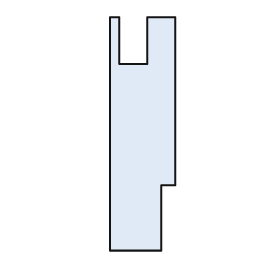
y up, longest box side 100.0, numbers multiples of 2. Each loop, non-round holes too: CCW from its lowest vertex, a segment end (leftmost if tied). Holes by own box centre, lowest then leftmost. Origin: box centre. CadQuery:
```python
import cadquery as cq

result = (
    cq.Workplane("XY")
    .moveTo(-14.0, -50.0)
    .lineTo(8.0, -50.0)
    .lineTo(8.0, -22.0)
    .lineTo(14.0, -22.0)
    .lineTo(14.0, 50.0)
    .lineTo(2.0, 50.0)
    .lineTo(2.0, 30.0)
    .lineTo(-10.0, 30.0)
    .lineTo(-10.0, 50.0)
    .lineTo(-14.0, 50.0)
    .close()
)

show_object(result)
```